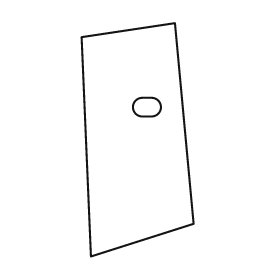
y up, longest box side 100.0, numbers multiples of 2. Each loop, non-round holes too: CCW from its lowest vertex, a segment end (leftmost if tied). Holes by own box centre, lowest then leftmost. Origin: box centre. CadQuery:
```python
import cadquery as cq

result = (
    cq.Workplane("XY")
    .moveTo(-20.0, -50.0)
    .lineTo(24.0, -36.0)
    .lineTo(16.0, 50.0)
    .lineTo(-24.0, 44.0)
    .close()
    .moveTo(2.0, 10.0)
    .lineTo(6.0, 10.0)
    .threePointArc((10.0, 14.0), (6.0, 18.0))
    .lineTo(2.0, 18.0)
    .threePointArc((-2.0, 14.0), (2.0, 10.0))
    .close()
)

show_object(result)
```